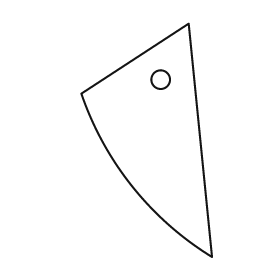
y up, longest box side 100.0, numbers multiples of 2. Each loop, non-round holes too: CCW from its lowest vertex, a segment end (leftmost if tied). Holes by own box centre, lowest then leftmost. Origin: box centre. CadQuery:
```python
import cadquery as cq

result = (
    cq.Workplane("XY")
    .moveTo(28.0, -50.0)
    .lineTo(18.0, 50.0)
    .lineTo(-28.0, 20.0)
    .threePointArc((-6.0, -20.0), (28.0, -50.0))
    .close()
    .moveTo(6.0, 26.0)
    .circle(4.0)
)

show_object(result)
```